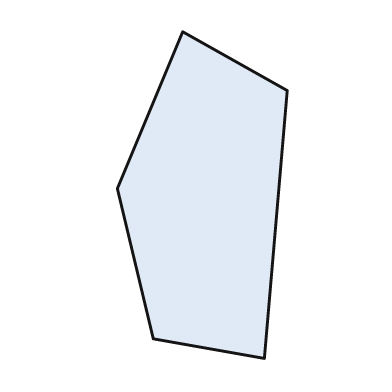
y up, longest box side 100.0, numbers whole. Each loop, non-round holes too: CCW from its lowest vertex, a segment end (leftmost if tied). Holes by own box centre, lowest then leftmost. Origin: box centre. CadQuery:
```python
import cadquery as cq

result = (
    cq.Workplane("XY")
    .moveTo(19.0, -50.0)
    .lineTo(26.0, 32.0)
    .lineTo(-6.0, 50.0)
    .lineTo(-26.0, 2.0)
    .lineTo(-15.0, -44.0)
    .close()
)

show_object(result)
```